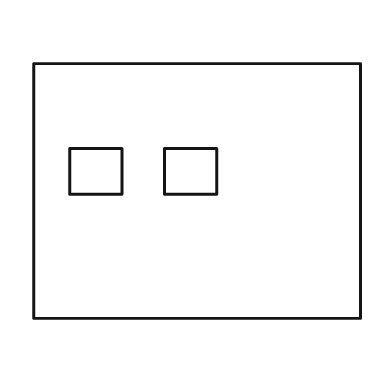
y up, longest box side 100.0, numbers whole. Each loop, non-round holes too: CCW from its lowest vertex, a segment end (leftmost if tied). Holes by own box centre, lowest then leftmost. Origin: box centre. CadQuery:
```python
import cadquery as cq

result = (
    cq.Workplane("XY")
    .moveTo(-50.0, -39.0)
    .lineTo(50.0, -39.0)
    .lineTo(50.0, 39.0)
    .lineTo(-50.0, 39.0)
    .close()
    .moveTo(-39.0, -1.0)
    .lineTo(-23.0, -1.0)
    .lineTo(-23.0, 13.0)
    .lineTo(-39.0, 13.0)
    .close()
    .moveTo(-10.0, -1.0)
    .lineTo(6.0, -1.0)
    .lineTo(6.0, 13.0)
    .lineTo(-10.0, 13.0)
    .close()
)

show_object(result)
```